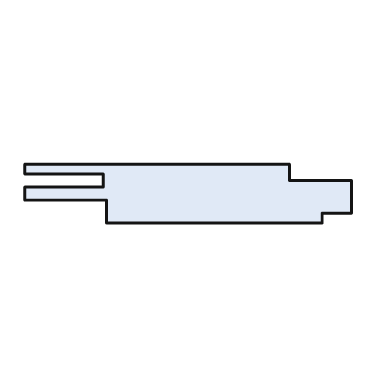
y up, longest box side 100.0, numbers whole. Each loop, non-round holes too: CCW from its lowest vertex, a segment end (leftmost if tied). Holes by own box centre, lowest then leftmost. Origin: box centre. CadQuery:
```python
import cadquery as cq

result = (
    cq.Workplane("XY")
    .moveTo(-25.0, -9.0)
    .lineTo(41.0, -9.0)
    .lineTo(41.0, -6.0)
    .lineTo(50.0, -6.0)
    .lineTo(50.0, 4.0)
    .lineTo(31.0, 4.0)
    .lineTo(31.0, 9.0)
    .lineTo(-50.0, 9.0)
    .lineTo(-50.0, 6.0)
    .lineTo(-26.0, 6.0)
    .lineTo(-26.0, 2.0)
    .lineTo(-50.0, 2.0)
    .lineTo(-50.0, -2.0)
    .lineTo(-25.0, -2.0)
    .close()
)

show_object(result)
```